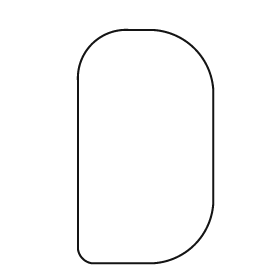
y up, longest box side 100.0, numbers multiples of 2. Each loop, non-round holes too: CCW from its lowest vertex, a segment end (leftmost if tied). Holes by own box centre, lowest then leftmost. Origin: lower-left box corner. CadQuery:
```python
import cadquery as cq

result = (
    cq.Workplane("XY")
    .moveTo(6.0, 0.0)
    .lineTo(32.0, 0.0)
    .threePointArc((50.0, 8.0), (58.0, 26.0))
    .lineTo(58.0, 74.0)
    .threePointArc((50.0, 92.0), (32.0, 100.0))
    .lineTo(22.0, 100.0)
    .threePointArc((6.0, 94.0), (0.0, 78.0))
    .lineTo(0.0, 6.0)
    .threePointArc((2.0, 2.0), (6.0, 0.0))
    .close()
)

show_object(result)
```